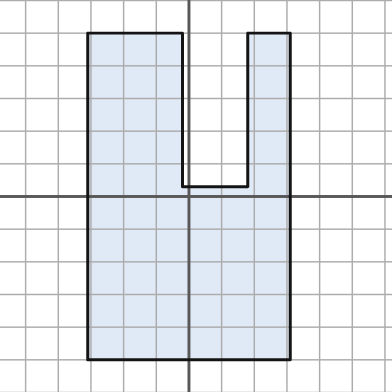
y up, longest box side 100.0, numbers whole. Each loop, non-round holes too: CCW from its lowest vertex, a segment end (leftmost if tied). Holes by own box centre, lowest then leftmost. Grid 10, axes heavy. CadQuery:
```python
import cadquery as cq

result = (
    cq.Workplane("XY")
    .moveTo(-31.0, -50.0)
    .lineTo(31.0, -50.0)
    .lineTo(31.0, 50.0)
    .lineTo(18.0, 50.0)
    .lineTo(18.0, 3.0)
    .lineTo(-2.0, 3.0)
    .lineTo(-2.0, 50.0)
    .lineTo(-31.0, 50.0)
    .close()
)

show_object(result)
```